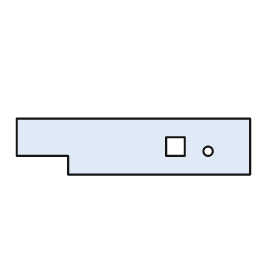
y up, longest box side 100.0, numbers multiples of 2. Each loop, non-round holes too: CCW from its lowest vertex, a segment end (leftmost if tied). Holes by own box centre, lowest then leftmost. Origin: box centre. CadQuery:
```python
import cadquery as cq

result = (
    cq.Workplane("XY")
    .moveTo(-28.0, -12.0)
    .lineTo(50.0, -12.0)
    .lineTo(50.0, 12.0)
    .lineTo(-50.0, 12.0)
    .lineTo(-50.0, -4.0)
    .lineTo(-28.0, -4.0)
    .close()
    .moveTo(32.0, -2.0)
    .circle(2.0)
    .moveTo(14.0, -4.0)
    .lineTo(22.0, -4.0)
    .lineTo(22.0, 4.0)
    .lineTo(14.0, 4.0)
    .close()
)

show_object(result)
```